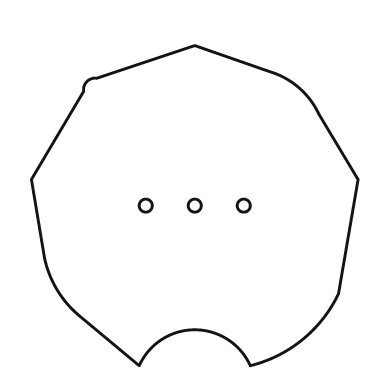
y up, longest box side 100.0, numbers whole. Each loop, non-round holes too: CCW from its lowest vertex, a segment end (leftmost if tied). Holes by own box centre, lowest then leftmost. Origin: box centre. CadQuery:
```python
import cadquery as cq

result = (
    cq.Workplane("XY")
    .moveTo(-17.0, -49.0)
    .threePointArc((0.0, -38.0), (17.0, -49.0))
    .threePointArc((33.0, -41.0), (44.0, -27.0))
    .lineTo(50.0, 8.0)
    .lineTo(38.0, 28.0)
    .threePointArc((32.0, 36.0), (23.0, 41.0))
    .lineTo(0.0, 49.0)
    .lineTo(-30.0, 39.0)
    .threePointArc((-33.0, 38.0), (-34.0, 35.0))
    .lineTo(-50.0, 8.0)
    .lineTo(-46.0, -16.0)
    .threePointArc((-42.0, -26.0), (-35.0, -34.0))
    .close()
    .moveTo(-15.0, 0.0)
    .circle(2.0)
    .moveTo(0.0, 0.0)
    .circle(2.0)
    .moveTo(15.0, 0.0)
    .circle(2.0)
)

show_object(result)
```